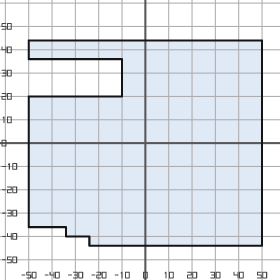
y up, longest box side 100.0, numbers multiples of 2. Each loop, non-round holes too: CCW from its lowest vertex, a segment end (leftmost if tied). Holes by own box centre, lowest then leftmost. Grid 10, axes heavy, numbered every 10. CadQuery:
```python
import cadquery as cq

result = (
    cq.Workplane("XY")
    .moveTo(-24.0, -44.0)
    .lineTo(50.0, -44.0)
    .lineTo(50.0, 44.0)
    .lineTo(-50.0, 44.0)
    .lineTo(-50.0, 36.0)
    .lineTo(-10.0, 36.0)
    .lineTo(-10.0, 20.0)
    .lineTo(-50.0, 20.0)
    .lineTo(-50.0, -36.0)
    .lineTo(-34.0, -36.0)
    .lineTo(-34.0, -40.0)
    .lineTo(-24.0, -40.0)
    .close()
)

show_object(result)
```